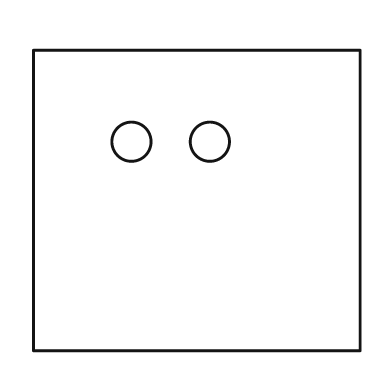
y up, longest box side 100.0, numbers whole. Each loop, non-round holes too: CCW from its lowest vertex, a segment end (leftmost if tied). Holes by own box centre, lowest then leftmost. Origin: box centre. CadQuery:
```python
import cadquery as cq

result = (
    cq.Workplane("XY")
    .moveTo(-50.0, -46.0)
    .lineTo(50.0, -46.0)
    .lineTo(50.0, 46.0)
    .lineTo(-50.0, 46.0)
    .close()
    .moveTo(-20.0, 18.0)
    .circle(6.0)
    .moveTo(4.0, 18.0)
    .circle(6.0)
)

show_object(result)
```